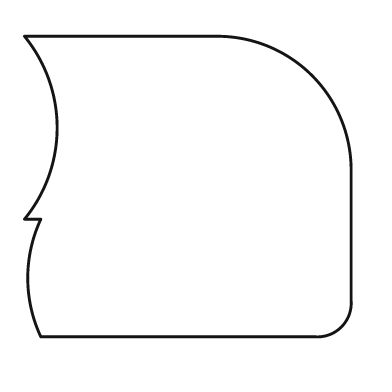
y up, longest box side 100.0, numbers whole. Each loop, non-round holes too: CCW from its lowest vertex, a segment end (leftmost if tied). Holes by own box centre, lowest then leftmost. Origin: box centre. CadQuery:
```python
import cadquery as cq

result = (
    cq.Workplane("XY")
    .moveTo(-45.0, -46.0)
    .lineTo(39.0, -46.0)
    .threePointArc((47.0, -43.0), (50.0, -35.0))
    .lineTo(50.0, 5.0)
    .threePointArc((38.0, 34.0), (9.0, 46.0))
    .lineTo(-50.0, 46.0)
    .threePointArc((-40.0, 18.0), (-50.0, -10.0))
    .lineTo(-45.0, -10.0)
    .threePointArc((-49.0, -28.0), (-45.0, -46.0))
    .close()
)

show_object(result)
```